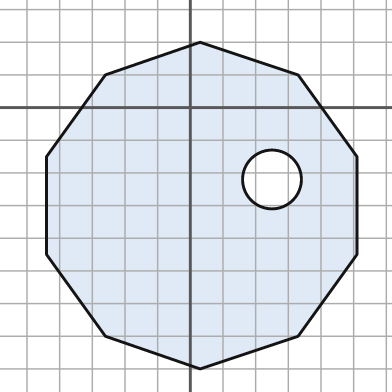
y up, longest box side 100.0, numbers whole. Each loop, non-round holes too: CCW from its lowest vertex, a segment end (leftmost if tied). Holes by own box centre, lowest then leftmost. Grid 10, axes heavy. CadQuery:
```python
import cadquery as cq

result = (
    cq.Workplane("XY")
    .moveTo(3.0, -80.0)
    .lineTo(33.0, -70.0)
    .lineTo(51.0, -45.0)
    .lineTo(51.0, -15.0)
    .lineTo(33.0, 10.0)
    .lineTo(3.0, 20.0)
    .lineTo(-26.0, 10.0)
    .lineTo(-44.0, -15.0)
    .lineTo(-44.0, -45.0)
    .lineTo(-26.0, -70.0)
    .close()
    .moveTo(25.0, -22.0)
    .circle(9.0)
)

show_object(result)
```